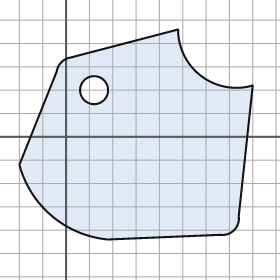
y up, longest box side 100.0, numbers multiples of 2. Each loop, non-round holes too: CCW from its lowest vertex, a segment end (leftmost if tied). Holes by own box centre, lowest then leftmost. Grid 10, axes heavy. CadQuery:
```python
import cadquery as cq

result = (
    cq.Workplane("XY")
    .moveTo(18.0, -44.0)
    .lineTo(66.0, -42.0)
    .threePointArc((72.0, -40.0), (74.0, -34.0))
    .lineTo(80.0, 22.0)
    .threePointArc((58.0, 26.0), (48.0, 46.0))
    .lineTo(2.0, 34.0)
    .threePointArc((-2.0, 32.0), (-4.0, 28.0))
    .lineTo(-20.0, -12.0)
    .threePointArc((-6.0, -34.0), (18.0, -44.0))
    .close()
    .moveTo(12.0, 20.0)
    .circle(6.0)
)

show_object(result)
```